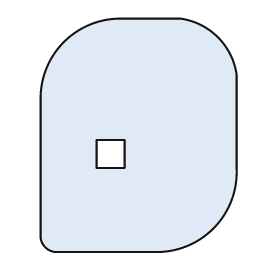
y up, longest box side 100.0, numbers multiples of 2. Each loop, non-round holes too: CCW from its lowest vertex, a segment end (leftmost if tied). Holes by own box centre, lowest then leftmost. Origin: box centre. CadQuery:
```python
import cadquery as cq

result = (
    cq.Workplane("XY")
    .moveTo(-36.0, -50.0)
    .lineTo(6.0, -50.0)
    .threePointArc((32.0, -40.0), (42.0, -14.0))
    .lineTo(42.0, 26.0)
    .threePointArc((34.0, 42.0), (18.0, 50.0))
    .lineTo(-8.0, 50.0)
    .threePointArc((-32.0, 40.0), (-42.0, 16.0))
    .lineTo(-42.0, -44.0)
    .threePointArc((-40.0, -48.0), (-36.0, -50.0))
    .close()
    .moveTo(-18.0, -14.0)
    .lineTo(-6.0, -14.0)
    .lineTo(-6.0, -2.0)
    .lineTo(-18.0, -2.0)
    .close()
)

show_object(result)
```